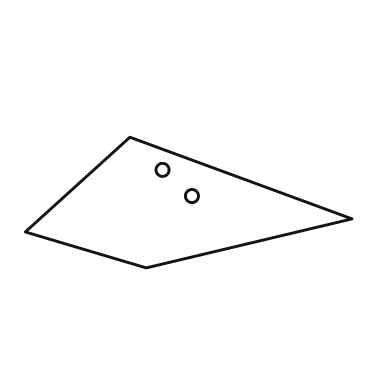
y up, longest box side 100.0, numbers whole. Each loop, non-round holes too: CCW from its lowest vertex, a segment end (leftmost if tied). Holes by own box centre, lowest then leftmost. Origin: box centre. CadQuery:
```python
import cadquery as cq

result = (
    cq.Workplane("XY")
    .moveTo(-13.0, -20.0)
    .lineTo(50.0, -5.0)
    .lineTo(-18.0, 20.0)
    .lineTo(-50.0, -9.0)
    .close()
    .moveTo(1.0, 2.0)
    .circle(2.0)
    .moveTo(-8.0, 10.0)
    .circle(2.0)
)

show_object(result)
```